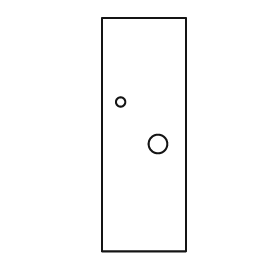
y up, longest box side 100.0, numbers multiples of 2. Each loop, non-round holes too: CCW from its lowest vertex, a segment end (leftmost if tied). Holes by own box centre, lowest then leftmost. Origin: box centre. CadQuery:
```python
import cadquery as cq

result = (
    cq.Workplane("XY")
    .moveTo(-18.0, -50.0)
    .lineTo(18.0, -50.0)
    .lineTo(18.0, 50.0)
    .lineTo(-18.0, 50.0)
    .close()
    .moveTo(6.0, -4.0)
    .circle(4.0)
    .moveTo(-10.0, 14.0)
    .circle(2.0)
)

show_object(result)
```